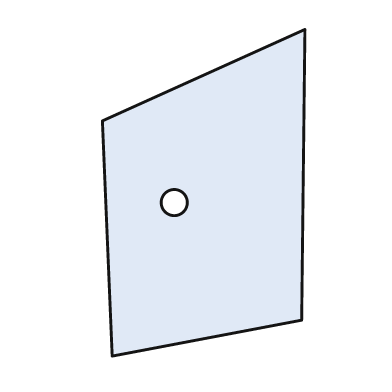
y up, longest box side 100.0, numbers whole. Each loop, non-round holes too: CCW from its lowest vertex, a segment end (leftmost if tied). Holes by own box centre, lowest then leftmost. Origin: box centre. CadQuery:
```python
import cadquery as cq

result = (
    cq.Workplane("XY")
    .moveTo(-28.0, -50.0)
    .lineTo(30.0, -39.0)
    .lineTo(31.0, 50.0)
    .lineTo(-31.0, 22.0)
    .close()
    .moveTo(-9.0, -3.0)
    .circle(4.0)
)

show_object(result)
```